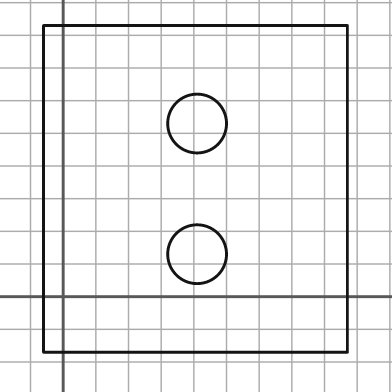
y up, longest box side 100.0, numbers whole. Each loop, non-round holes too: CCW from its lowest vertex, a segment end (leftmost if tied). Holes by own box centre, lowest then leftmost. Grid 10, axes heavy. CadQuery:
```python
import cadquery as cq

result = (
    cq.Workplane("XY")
    .moveTo(-6.0, -17.0)
    .lineTo(87.0, -17.0)
    .lineTo(87.0, 83.0)
    .lineTo(-6.0, 83.0)
    .close()
    .moveTo(41.0, 13.0)
    .circle(9.0)
    .moveTo(41.0, 53.0)
    .circle(9.0)
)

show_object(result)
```